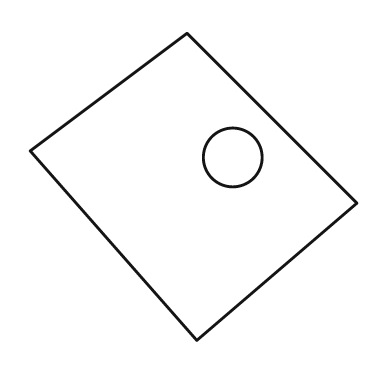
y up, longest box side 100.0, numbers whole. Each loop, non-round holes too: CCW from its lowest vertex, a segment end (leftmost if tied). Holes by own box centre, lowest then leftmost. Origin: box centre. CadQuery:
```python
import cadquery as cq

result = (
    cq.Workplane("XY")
    .moveTo(1.0, -47.0)
    .lineTo(50.0, -5.0)
    .lineTo(-2.0, 47.0)
    .lineTo(-50.0, 11.0)
    .close()
    .moveTo(12.0, 9.0)
    .circle(9.0)
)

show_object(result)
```